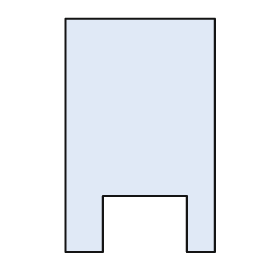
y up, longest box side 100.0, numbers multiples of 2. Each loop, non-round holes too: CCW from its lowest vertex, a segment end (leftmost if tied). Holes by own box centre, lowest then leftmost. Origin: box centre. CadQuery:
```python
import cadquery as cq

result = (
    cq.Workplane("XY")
    .moveTo(-32.0, -50.0)
    .lineTo(-16.0, -50.0)
    .lineTo(-16.0, -26.0)
    .lineTo(20.0, -26.0)
    .lineTo(20.0, -50.0)
    .lineTo(32.0, -50.0)
    .lineTo(32.0, 50.0)
    .lineTo(-32.0, 50.0)
    .close()
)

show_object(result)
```